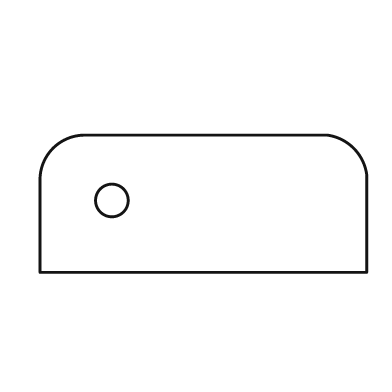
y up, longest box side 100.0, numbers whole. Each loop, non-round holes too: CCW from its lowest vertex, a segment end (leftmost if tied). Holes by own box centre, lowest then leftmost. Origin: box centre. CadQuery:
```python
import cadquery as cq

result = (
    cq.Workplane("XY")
    .moveTo(-50.0, -21.0)
    .lineTo(50.0, -21.0)
    .lineTo(50.0, 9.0)
    .threePointArc((46.0, 17.0), (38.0, 21.0))
    .lineTo(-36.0, 21.0)
    .threePointArc((-46.0, 17.0), (-50.0, 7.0))
    .close()
    .moveTo(-28.0, 1.0)
    .circle(5.0)
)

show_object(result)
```